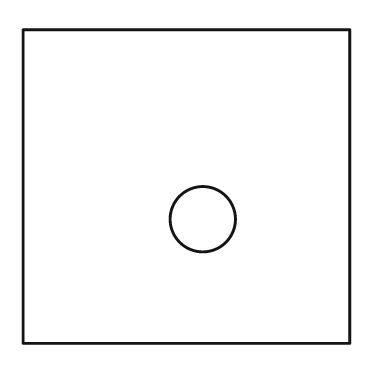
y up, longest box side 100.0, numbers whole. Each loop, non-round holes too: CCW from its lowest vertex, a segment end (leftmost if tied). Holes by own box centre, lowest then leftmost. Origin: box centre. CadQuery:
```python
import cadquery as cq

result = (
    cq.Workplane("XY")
    .moveTo(-50.0, -48.0)
    .lineTo(50.0, -48.0)
    .lineTo(50.0, 48.0)
    .lineTo(-50.0, 48.0)
    .close()
    .moveTo(5.0, -10.0)
    .circle(10.0)
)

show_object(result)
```